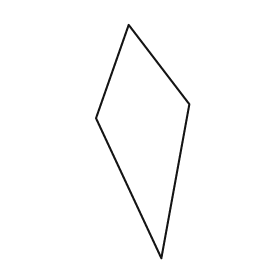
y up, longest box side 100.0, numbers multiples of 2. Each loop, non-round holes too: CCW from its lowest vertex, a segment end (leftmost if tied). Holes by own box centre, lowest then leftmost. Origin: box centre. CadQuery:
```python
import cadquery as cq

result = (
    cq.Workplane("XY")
    .moveTo(8.0, -50.0)
    .lineTo(20.0, 16.0)
    .lineTo(-6.0, 50.0)
    .lineTo(-20.0, 10.0)
    .close()
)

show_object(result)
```